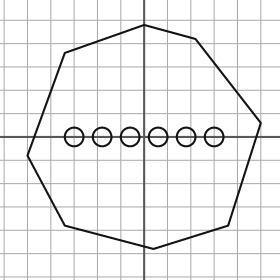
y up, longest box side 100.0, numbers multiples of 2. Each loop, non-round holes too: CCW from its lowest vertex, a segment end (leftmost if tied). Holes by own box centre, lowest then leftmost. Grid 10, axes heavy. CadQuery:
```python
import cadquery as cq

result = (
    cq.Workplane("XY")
    .moveTo(4.0, -48.0)
    .lineTo(36.0, -38.0)
    .lineTo(50.0, 6.0)
    .lineTo(22.0, 42.0)
    .lineTo(0.0, 48.0)
    .lineTo(-34.0, 36.0)
    .lineTo(-50.0, -8.0)
    .lineTo(-34.0, -38.0)
    .close()
    .moveTo(-30.0, 0.0)
    .circle(4.0)
    .moveTo(-18.0, 0.0)
    .circle(4.0)
    .moveTo(-6.0, 0.0)
    .circle(4.0)
    .moveTo(6.0, 0.0)
    .circle(4.0)
    .moveTo(18.0, 0.0)
    .circle(4.0)
    .moveTo(30.0, 0.0)
    .circle(4.0)
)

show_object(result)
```